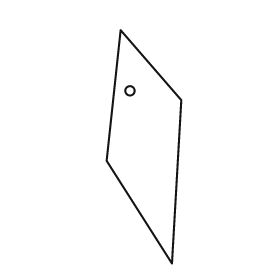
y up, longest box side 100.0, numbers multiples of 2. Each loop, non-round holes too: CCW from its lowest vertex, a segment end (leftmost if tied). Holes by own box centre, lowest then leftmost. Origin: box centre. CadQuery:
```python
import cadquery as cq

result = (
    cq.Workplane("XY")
    .moveTo(12.0, -50.0)
    .lineTo(16.0, 20.0)
    .lineTo(-10.0, 50.0)
    .lineTo(-16.0, -6.0)
    .close()
    .moveTo(-6.0, 24.0)
    .circle(2.0)
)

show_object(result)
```